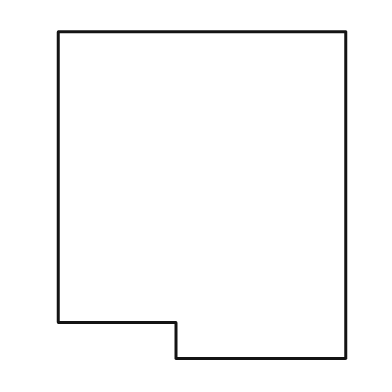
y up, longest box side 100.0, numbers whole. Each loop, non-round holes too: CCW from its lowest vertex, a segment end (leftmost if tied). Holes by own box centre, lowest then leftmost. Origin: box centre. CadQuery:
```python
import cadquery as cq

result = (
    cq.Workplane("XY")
    .moveTo(-8.0, -50.0)
    .lineTo(44.0, -50.0)
    .lineTo(44.0, 50.0)
    .lineTo(-44.0, 50.0)
    .lineTo(-44.0, -39.0)
    .lineTo(-8.0, -39.0)
    .close()
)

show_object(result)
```